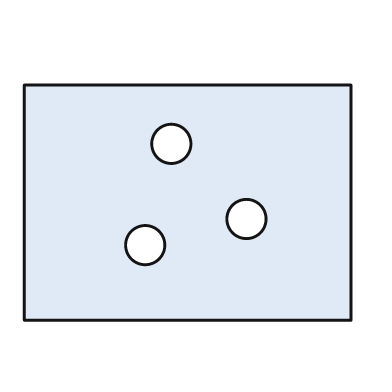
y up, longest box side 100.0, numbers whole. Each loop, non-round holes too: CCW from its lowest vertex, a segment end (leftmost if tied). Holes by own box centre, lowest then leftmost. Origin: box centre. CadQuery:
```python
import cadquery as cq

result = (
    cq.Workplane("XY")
    .moveTo(-50.0, -36.0)
    .lineTo(50.0, -36.0)
    .lineTo(50.0, 36.0)
    .lineTo(-50.0, 36.0)
    .close()
    .moveTo(-13.0, -13.0)
    .circle(6.0)
    .moveTo(18.0, -5.0)
    .circle(6.0)
    .moveTo(-5.0, 18.0)
    .circle(6.0)
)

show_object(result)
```